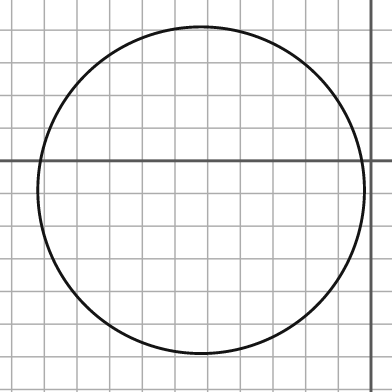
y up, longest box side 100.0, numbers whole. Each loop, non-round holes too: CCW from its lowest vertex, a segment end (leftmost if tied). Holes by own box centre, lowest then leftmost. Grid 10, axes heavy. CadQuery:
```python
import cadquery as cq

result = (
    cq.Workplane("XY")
    .moveTo(-52.0, -9.0)
    .circle(50.0)
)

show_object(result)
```